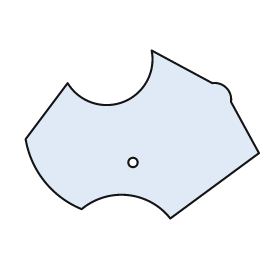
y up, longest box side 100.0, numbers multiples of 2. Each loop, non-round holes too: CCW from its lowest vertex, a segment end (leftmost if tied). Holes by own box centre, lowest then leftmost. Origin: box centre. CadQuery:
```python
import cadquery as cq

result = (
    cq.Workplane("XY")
    .moveTo(12.0, -36.0)
    .lineTo(50.0, -8.0)
    .lineTo(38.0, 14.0)
    .threePointArc((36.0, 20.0), (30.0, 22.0))
    .lineTo(4.0, 36.0)
    .threePointArc((-8.0, 14.0), (-32.0, 22.0))
    .lineTo(-50.0, -2.0)
    .threePointArc((-42.0, -20.0), (-26.0, -32.0))
    .threePointArc((-6.0, -26.0), (12.0, -36.0))
    .close()
    .moveTo(-4.0, -12.0)
    .circle(2.0)
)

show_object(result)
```